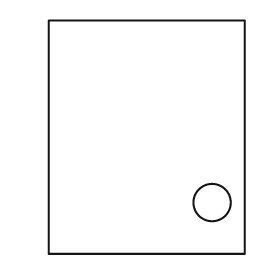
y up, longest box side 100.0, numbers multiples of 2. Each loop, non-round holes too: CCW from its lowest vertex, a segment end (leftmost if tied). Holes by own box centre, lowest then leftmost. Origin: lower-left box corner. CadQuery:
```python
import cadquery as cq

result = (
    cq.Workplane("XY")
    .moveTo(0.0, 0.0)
    .lineTo(84.0, 0.0)
    .lineTo(84.0, 100.0)
    .lineTo(0.0, 100.0)
    .close()
    .moveTo(70.0, 22.0)
    .circle(8.0)
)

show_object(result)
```